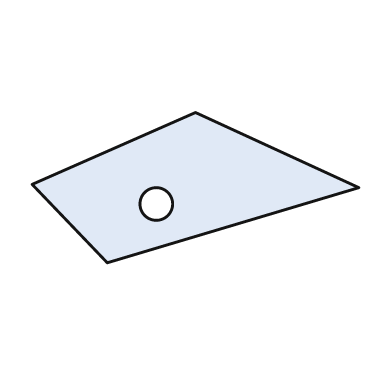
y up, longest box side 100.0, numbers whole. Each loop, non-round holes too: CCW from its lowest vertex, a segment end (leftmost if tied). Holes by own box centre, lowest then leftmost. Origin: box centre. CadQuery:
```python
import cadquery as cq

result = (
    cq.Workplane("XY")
    .moveTo(-27.0, -23.0)
    .lineTo(50.0, 0.0)
    .lineTo(0.0, 23.0)
    .lineTo(-50.0, 1.0)
    .close()
    .moveTo(-12.0, -5.0)
    .circle(5.0)
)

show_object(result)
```